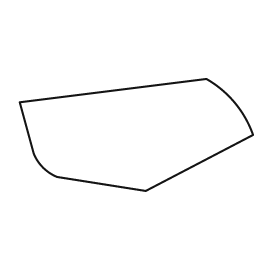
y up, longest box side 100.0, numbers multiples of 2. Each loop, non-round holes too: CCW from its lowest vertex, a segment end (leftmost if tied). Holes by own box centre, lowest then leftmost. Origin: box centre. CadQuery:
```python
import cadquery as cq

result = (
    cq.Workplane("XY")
    .moveTo(4.0, -24.0)
    .lineTo(50.0, 0.0)
    .threePointArc((42.0, 14.0), (30.0, 24.0))
    .lineTo(-50.0, 14.0)
    .lineTo(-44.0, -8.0)
    .threePointArc((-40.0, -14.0), (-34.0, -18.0))
    .close()
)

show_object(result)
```